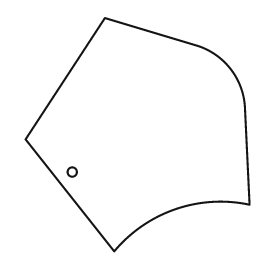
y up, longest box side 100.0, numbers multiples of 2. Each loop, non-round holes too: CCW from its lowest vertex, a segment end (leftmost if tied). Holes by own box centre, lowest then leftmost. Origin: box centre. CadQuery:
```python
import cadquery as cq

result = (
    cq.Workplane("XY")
    .moveTo(-10.0, -50.0)
    .threePointArc((16.0, -32.0), (48.0, -30.0))
    .lineTo(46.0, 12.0)
    .threePointArc((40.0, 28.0), (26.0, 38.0))
    .lineTo(-14.0, 50.0)
    .lineTo(-48.0, -2.0)
    .close()
    .moveTo(-28.0, -16.0)
    .circle(2.0)
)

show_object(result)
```